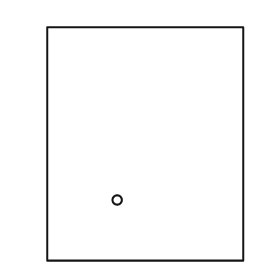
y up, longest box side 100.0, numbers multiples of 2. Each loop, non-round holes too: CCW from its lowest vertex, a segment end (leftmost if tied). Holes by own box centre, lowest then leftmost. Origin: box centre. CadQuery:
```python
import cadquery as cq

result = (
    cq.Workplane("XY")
    .moveTo(-42.0, -50.0)
    .lineTo(42.0, -50.0)
    .lineTo(42.0, 50.0)
    .lineTo(-42.0, 50.0)
    .close()
    .moveTo(-12.0, -24.0)
    .circle(2.0)
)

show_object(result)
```